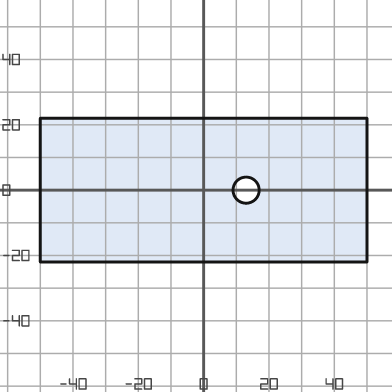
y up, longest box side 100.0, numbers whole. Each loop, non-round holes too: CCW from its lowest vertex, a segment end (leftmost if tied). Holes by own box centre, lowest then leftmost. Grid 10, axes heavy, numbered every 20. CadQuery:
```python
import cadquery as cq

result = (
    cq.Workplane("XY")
    .moveTo(-50.0, -22.0)
    .lineTo(50.0, -22.0)
    .lineTo(50.0, 22.0)
    .lineTo(-50.0, 22.0)
    .close()
    .moveTo(13.0, 0.0)
    .circle(4.0)
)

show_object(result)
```